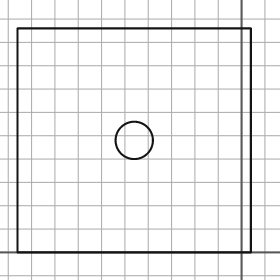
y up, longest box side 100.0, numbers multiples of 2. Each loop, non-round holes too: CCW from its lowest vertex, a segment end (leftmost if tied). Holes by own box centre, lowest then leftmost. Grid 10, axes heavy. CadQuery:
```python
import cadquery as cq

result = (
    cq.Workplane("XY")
    .moveTo(-96.0, 0.0)
    .lineTo(4.0, 0.0)
    .lineTo(4.0, 96.0)
    .lineTo(-96.0, 96.0)
    .close()
    .moveTo(-46.0, 48.0)
    .circle(8.0)
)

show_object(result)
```